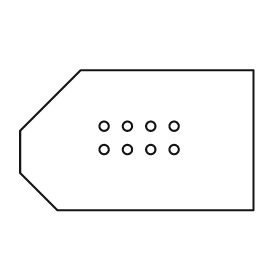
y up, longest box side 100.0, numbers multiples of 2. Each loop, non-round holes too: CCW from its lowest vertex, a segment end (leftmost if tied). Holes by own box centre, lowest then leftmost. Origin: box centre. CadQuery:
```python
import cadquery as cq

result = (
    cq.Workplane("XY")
    .moveTo(-34.0, -30.0)
    .lineTo(50.0, -30.0)
    .lineTo(50.0, 30.0)
    .lineTo(-24.0, 30.0)
    .lineTo(-50.0, 4.0)
    .lineTo(-50.0, -14.0)
    .close()
    .moveTo(-14.0, -4.0)
    .circle(2.0)
    .moveTo(-4.0, -4.0)
    .circle(2.0)
    .moveTo(6.0, -4.0)
    .circle(2.0)
    .moveTo(16.0, -4.0)
    .circle(2.0)
    .moveTo(-14.0, 6.0)
    .circle(2.0)
    .moveTo(-4.0, 6.0)
    .circle(2.0)
    .moveTo(6.0, 6.0)
    .circle(2.0)
    .moveTo(16.0, 6.0)
    .circle(2.0)
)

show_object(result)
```